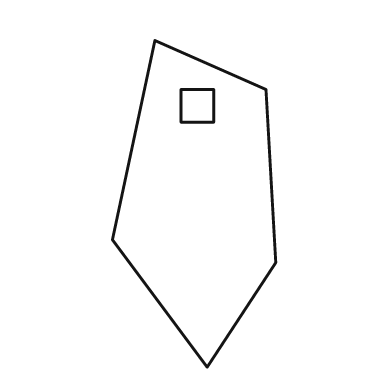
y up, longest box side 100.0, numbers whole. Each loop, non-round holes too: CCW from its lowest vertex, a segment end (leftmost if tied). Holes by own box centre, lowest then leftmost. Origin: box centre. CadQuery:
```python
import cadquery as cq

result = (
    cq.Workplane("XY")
    .moveTo(4.0, -50.0)
    .lineTo(25.0, -18.0)
    .lineTo(22.0, 35.0)
    .lineTo(-12.0, 50.0)
    .lineTo(-25.0, -11.0)
    .close()
    .moveTo(-4.0, 25.0)
    .lineTo(6.0, 25.0)
    .lineTo(6.0, 35.0)
    .lineTo(-4.0, 35.0)
    .close()
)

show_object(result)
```